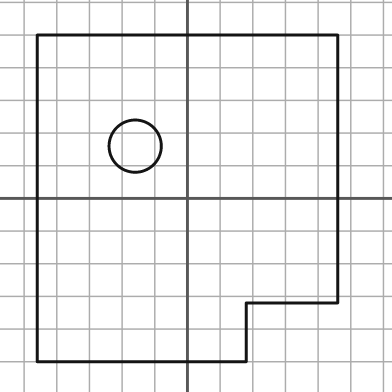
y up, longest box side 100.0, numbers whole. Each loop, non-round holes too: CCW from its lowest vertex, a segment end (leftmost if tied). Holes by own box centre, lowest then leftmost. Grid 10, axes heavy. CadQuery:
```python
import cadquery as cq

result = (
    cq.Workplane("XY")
    .moveTo(-46.0, -50.0)
    .lineTo(18.0, -50.0)
    .lineTo(18.0, -32.0)
    .lineTo(46.0, -32.0)
    .lineTo(46.0, 50.0)
    .lineTo(-46.0, 50.0)
    .close()
    .moveTo(-16.0, 16.0)
    .circle(8.0)
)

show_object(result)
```